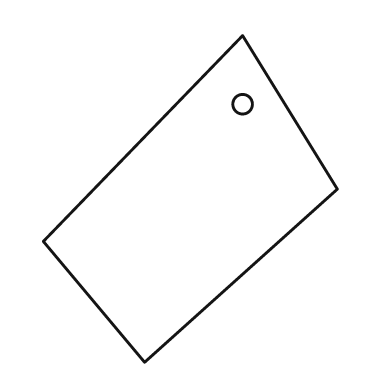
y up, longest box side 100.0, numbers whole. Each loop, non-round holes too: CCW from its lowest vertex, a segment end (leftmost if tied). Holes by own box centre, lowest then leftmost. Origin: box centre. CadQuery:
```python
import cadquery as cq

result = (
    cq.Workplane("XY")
    .moveTo(-14.0, -50.0)
    .lineTo(45.0, 3.0)
    .lineTo(16.0, 50.0)
    .lineTo(-45.0, -13.0)
    .close()
    .moveTo(16.0, 29.0)
    .circle(3.0)
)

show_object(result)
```